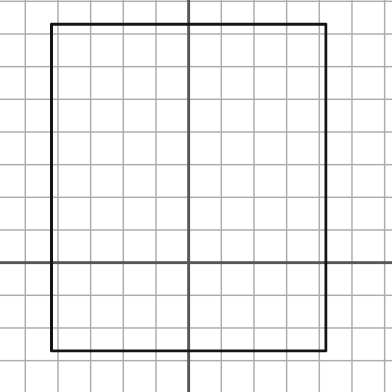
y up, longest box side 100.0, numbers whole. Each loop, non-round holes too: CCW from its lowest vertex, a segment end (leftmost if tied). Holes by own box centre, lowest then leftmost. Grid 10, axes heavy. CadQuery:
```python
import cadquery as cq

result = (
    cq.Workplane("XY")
    .moveTo(-42.0, -27.0)
    .lineTo(42.0, -27.0)
    .lineTo(42.0, 73.0)
    .lineTo(-42.0, 73.0)
    .close()
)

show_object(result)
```